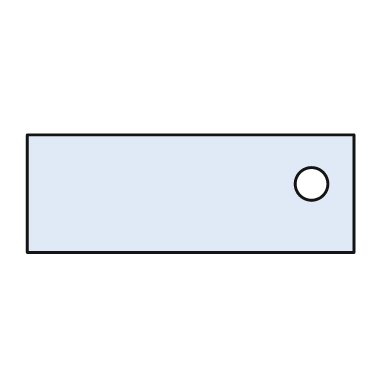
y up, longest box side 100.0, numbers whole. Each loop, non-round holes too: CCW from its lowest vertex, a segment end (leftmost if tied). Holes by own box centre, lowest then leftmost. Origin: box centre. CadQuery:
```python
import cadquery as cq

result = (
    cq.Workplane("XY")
    .moveTo(-50.0, -18.0)
    .lineTo(50.0, -18.0)
    .lineTo(50.0, 18.0)
    .lineTo(-50.0, 18.0)
    .close()
    .moveTo(37.0, 3.0)
    .circle(5.0)
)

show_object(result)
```